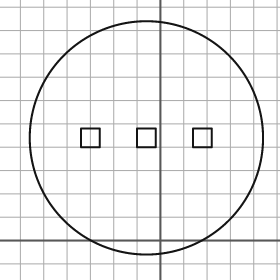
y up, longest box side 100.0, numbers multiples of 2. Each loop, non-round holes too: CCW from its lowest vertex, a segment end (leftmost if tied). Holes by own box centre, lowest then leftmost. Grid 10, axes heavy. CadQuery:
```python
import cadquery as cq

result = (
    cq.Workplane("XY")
    .moveTo(-6.0, 44.0)
    .circle(50.0)
    .moveTo(-34.0, 40.0)
    .lineTo(-26.0, 40.0)
    .lineTo(-26.0, 48.0)
    .lineTo(-34.0, 48.0)
    .close()
    .moveTo(-10.0, 40.0)
    .lineTo(-2.0, 40.0)
    .lineTo(-2.0, 48.0)
    .lineTo(-10.0, 48.0)
    .close()
    .moveTo(14.0, 40.0)
    .lineTo(22.0, 40.0)
    .lineTo(22.0, 48.0)
    .lineTo(14.0, 48.0)
    .close()
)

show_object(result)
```